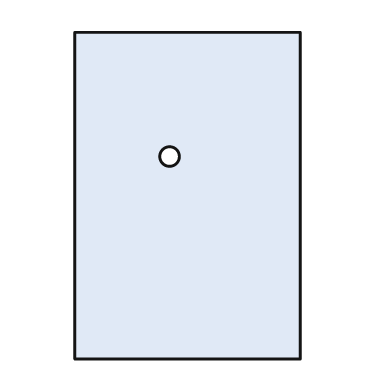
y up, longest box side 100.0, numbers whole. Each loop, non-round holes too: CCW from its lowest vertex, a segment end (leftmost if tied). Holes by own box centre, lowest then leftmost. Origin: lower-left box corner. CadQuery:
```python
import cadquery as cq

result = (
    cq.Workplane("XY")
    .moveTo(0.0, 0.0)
    .lineTo(69.0, 0.0)
    .lineTo(69.0, 100.0)
    .lineTo(0.0, 100.0)
    .close()
    .moveTo(29.0, 62.0)
    .circle(3.0)
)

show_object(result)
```